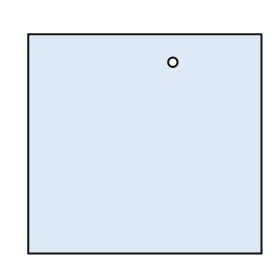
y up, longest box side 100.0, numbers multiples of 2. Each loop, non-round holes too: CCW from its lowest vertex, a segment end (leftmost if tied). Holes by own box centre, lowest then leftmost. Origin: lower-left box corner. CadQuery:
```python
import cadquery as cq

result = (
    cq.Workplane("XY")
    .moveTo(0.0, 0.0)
    .lineTo(100.0, 0.0)
    .lineTo(100.0, 94.0)
    .lineTo(0.0, 94.0)
    .close()
    .moveTo(62.0, 82.0)
    .circle(2.0)
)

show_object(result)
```